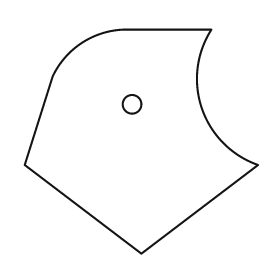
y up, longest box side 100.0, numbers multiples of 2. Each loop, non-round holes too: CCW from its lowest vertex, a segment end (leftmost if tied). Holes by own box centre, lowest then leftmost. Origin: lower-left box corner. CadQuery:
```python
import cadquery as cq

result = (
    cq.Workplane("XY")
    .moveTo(50.0, 0.0)
    .lineTo(100.0, 38.0)
    .threePointArc((76.0, 62.0), (80.0, 96.0))
    .lineTo(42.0, 96.0)
    .threePointArc((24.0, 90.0), (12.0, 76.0))
    .lineTo(0.0, 38.0)
    .close()
    .moveTo(46.0, 64.0)
    .circle(4.0)
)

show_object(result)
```